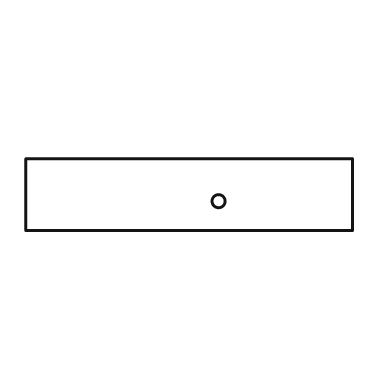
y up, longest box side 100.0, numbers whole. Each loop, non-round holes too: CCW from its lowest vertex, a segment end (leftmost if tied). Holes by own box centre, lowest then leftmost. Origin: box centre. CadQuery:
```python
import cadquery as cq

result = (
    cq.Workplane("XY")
    .moveTo(-50.0, -11.0)
    .lineTo(50.0, -11.0)
    .lineTo(50.0, 11.0)
    .lineTo(-50.0, 11.0)
    .close()
    .moveTo(9.0, -2.0)
    .circle(2.0)
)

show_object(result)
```